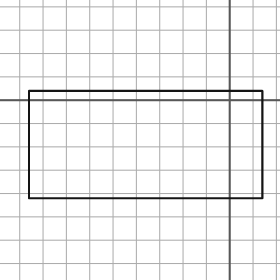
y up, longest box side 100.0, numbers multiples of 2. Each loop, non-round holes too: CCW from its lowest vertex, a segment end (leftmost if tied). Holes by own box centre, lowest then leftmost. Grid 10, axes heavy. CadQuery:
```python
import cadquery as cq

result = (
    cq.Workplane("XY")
    .moveTo(-86.0, -42.0)
    .lineTo(14.0, -42.0)
    .lineTo(14.0, 4.0)
    .lineTo(-86.0, 4.0)
    .close()
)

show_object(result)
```